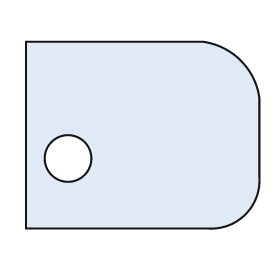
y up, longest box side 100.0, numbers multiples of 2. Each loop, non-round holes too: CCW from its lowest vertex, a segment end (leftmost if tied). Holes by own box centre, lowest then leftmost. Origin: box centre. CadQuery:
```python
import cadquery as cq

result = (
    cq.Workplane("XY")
    .moveTo(-50.0, -40.0)
    .lineTo(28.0, -40.0)
    .threePointArc((44.0, -34.0), (50.0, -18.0))
    .lineTo(50.0, 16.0)
    .threePointArc((42.0, 32.0), (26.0, 40.0))
    .lineTo(-50.0, 40.0)
    .close()
    .moveTo(-32.0, -10.0)
    .circle(10.0)
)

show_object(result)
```